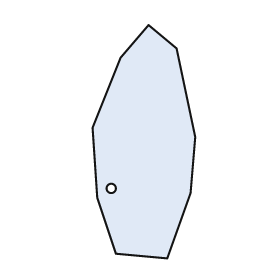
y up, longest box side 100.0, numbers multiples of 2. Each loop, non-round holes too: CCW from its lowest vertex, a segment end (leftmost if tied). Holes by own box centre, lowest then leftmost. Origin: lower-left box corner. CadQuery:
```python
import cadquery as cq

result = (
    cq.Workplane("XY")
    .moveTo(32.0, 0.0)
    .lineTo(42.0, 28.0)
    .lineTo(44.0, 52.0)
    .lineTo(36.0, 90.0)
    .lineTo(24.0, 100.0)
    .lineTo(12.0, 86.0)
    .lineTo(0.0, 56.0)
    .lineTo(2.0, 26.0)
    .lineTo(10.0, 2.0)
    .close()
    .moveTo(8.0, 30.0)
    .circle(2.0)
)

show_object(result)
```